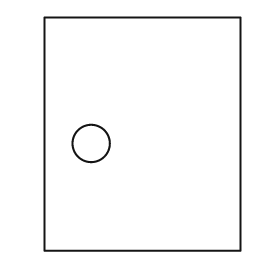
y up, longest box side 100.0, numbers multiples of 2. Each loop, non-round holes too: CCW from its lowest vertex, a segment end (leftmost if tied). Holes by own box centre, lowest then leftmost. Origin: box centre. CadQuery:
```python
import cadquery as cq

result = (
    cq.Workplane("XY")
    .moveTo(-42.0, -50.0)
    .lineTo(42.0, -50.0)
    .lineTo(42.0, 50.0)
    .lineTo(-42.0, 50.0)
    .close()
    .moveTo(-22.0, -4.0)
    .circle(8.0)
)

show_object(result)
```